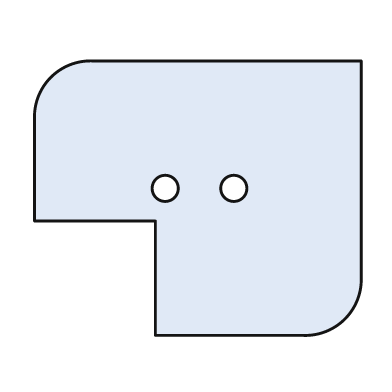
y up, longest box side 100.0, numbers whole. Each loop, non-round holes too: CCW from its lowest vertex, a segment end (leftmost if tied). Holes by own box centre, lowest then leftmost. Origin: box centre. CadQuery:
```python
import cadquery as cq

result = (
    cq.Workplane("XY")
    .moveTo(-13.0, -42.0)
    .lineTo(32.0, -42.0)
    .threePointArc((45.0, -37.0), (50.0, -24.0))
    .lineTo(50.0, 42.0)
    .lineTo(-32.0, 42.0)
    .threePointArc((-45.0, 37.0), (-50.0, 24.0))
    .lineTo(-50.0, -7.0)
    .lineTo(-13.0, -7.0)
    .close()
    .moveTo(-10.0, 3.0)
    .circle(4.0)
    .moveTo(11.0, 3.0)
    .circle(4.0)
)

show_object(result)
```